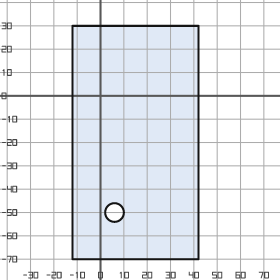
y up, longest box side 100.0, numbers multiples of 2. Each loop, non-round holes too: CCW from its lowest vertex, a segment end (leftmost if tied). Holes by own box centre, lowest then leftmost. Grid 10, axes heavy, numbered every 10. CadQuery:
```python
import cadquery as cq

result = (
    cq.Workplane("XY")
    .moveTo(-12.0, -70.0)
    .lineTo(42.0, -70.0)
    .lineTo(42.0, 30.0)
    .lineTo(-12.0, 30.0)
    .close()
    .moveTo(6.0, -50.0)
    .circle(4.0)
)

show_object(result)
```